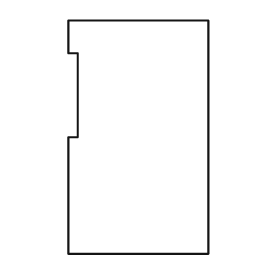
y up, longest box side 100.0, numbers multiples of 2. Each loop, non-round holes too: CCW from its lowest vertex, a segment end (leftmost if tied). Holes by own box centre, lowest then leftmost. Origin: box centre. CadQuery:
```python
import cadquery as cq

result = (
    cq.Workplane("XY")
    .moveTo(-30.0, -50.0)
    .lineTo(30.0, -50.0)
    .lineTo(30.0, 50.0)
    .lineTo(-30.0, 50.0)
    .lineTo(-30.0, 36.0)
    .lineTo(-26.0, 36.0)
    .lineTo(-26.0, 0.0)
    .lineTo(-30.0, 0.0)
    .close()
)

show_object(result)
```